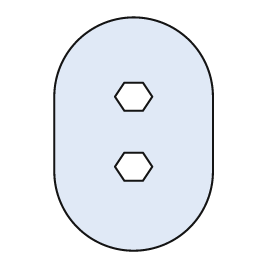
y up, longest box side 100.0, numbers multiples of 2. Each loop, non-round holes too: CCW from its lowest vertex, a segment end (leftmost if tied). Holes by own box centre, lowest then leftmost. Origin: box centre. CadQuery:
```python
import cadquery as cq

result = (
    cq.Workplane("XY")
    .moveTo(-34.0, -16.0)
    .threePointArc((0.0, -50.0), (34.0, -16.0))
    .lineTo(34.0, 16.0)
    .threePointArc((0.0, 50.0), (-34.0, 16.0))
    .close()
    .moveTo(-4.0, -20.0)
    .lineTo(4.0, -20.0)
    .lineTo(8.0, -14.0)
    .lineTo(4.0, -8.0)
    .lineTo(-4.0, -8.0)
    .lineTo(-8.0, -14.0)
    .close()
    .moveTo(-4.0, 10.0)
    .lineTo(4.0, 10.0)
    .lineTo(8.0, 16.0)
    .lineTo(4.0, 22.0)
    .lineTo(-4.0, 22.0)
    .lineTo(-8.0, 16.0)
    .close()
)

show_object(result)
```